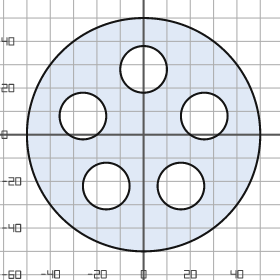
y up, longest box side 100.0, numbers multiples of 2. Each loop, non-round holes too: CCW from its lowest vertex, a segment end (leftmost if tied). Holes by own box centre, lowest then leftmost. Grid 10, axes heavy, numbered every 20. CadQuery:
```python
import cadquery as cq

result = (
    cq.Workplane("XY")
    .moveTo(0.0, 0.0)
    .circle(50.0)
    .moveTo(-16.0, -22.0)
    .circle(10.0)
    .moveTo(16.0, -22.0)
    .circle(10.0)
    .moveTo(-26.0, 8.0)
    .circle(10.0)
    .moveTo(26.0, 8.0)
    .circle(10.0)
    .moveTo(0.0, 28.0)
    .circle(10.0)
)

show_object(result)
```